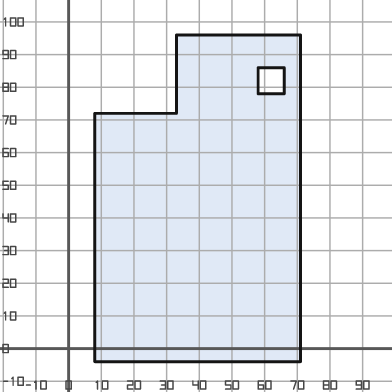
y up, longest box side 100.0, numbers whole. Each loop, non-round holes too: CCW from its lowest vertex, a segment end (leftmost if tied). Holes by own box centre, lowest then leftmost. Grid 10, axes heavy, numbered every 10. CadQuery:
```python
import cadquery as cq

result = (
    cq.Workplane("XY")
    .moveTo(8.0, -4.0)
    .lineTo(71.0, -4.0)
    .lineTo(71.0, 96.0)
    .lineTo(33.0, 96.0)
    .lineTo(33.0, 72.0)
    .lineTo(8.0, 72.0)
    .close()
    .moveTo(58.0, 78.0)
    .lineTo(66.0, 78.0)
    .lineTo(66.0, 86.0)
    .lineTo(58.0, 86.0)
    .close()
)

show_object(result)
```